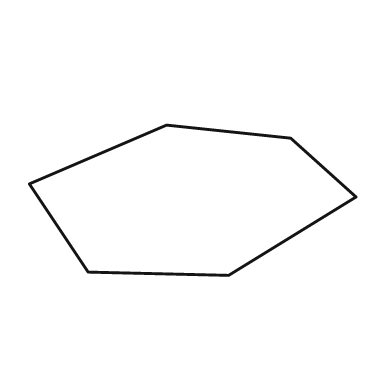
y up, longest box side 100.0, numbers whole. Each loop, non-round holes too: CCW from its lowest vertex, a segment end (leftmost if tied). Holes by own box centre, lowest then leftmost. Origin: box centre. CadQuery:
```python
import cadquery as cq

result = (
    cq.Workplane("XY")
    .moveTo(11.0, -23.0)
    .lineTo(50.0, 1.0)
    .lineTo(30.0, 19.0)
    .lineTo(-8.0, 23.0)
    .lineTo(-50.0, 5.0)
    .lineTo(-32.0, -22.0)
    .close()
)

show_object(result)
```